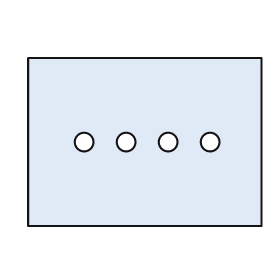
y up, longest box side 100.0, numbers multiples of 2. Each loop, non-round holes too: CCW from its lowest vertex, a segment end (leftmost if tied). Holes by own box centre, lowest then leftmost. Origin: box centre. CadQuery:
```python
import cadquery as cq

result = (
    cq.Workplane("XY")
    .moveTo(-50.0, -36.0)
    .lineTo(50.0, -36.0)
    .lineTo(50.0, 36.0)
    .lineTo(-50.0, 36.0)
    .close()
    .moveTo(-26.0, 0.0)
    .circle(4.0)
    .moveTo(-8.0, 0.0)
    .circle(4.0)
    .moveTo(10.0, 0.0)
    .circle(4.0)
    .moveTo(28.0, 0.0)
    .circle(4.0)
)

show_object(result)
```